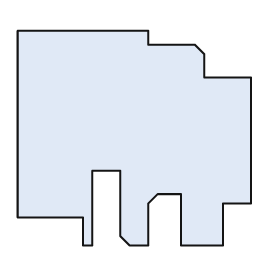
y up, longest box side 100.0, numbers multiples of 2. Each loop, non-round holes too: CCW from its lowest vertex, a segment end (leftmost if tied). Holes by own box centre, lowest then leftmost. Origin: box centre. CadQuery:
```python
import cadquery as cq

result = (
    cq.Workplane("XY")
    .moveTo(-22.0, -46.0)
    .lineTo(-18.0, -46.0)
    .lineTo(-18.0, -14.0)
    .lineTo(-6.0, -14.0)
    .lineTo(-6.0, -42.0)
    .lineTo(-2.0, -46.0)
    .lineTo(6.0, -46.0)
    .lineTo(6.0, -28.0)
    .lineTo(10.0, -24.0)
    .lineTo(20.0, -24.0)
    .lineTo(20.0, -46.0)
    .lineTo(38.0, -46.0)
    .lineTo(38.0, -28.0)
    .lineTo(50.0, -28.0)
    .lineTo(50.0, 26.0)
    .lineTo(30.0, 26.0)
    .lineTo(30.0, 36.0)
    .lineTo(26.0, 40.0)
    .lineTo(6.0, 40.0)
    .lineTo(6.0, 46.0)
    .lineTo(-50.0, 46.0)
    .lineTo(-50.0, -34.0)
    .lineTo(-22.0, -34.0)
    .close()
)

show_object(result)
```